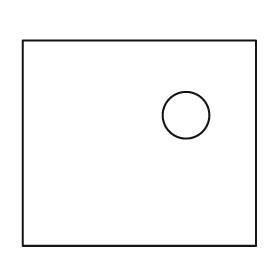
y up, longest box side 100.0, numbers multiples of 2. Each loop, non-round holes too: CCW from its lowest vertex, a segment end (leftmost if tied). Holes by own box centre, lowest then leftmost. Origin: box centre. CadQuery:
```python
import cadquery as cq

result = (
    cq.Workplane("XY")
    .moveTo(-50.0, -44.0)
    .lineTo(50.0, -44.0)
    .lineTo(50.0, 44.0)
    .lineTo(-50.0, 44.0)
    .close()
    .moveTo(20.0, 12.0)
    .circle(10.0)
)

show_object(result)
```